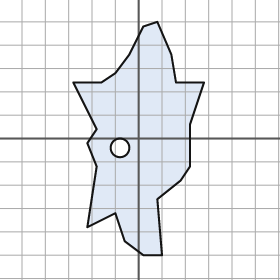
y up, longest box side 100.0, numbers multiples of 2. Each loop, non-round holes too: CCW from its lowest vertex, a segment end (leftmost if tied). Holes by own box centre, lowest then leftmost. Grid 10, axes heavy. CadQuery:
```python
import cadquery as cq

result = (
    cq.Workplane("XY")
    .moveTo(2.0, -50.0)
    .lineTo(10.0, -50.0)
    .lineTo(8.0, -26.0)
    .lineTo(18.0, -18.0)
    .lineTo(22.0, -12.0)
    .lineTo(22.0, 6.0)
    .lineTo(28.0, 24.0)
    .lineTo(16.0, 24.0)
    .lineTo(14.0, 36.0)
    .lineTo(8.0, 50.0)
    .lineTo(2.0, 48.0)
    .lineTo(-4.0, 36.0)
    .lineTo(-10.0, 28.0)
    .lineTo(-16.0, 24.0)
    .lineTo(-28.0, 24.0)
    .lineTo(-18.0, 4.0)
    .lineTo(-22.0, -2.0)
    .lineTo(-18.0, -12.0)
    .lineTo(-22.0, -38.0)
    .lineTo(-10.0, -32.0)
    .lineTo(-6.0, -44.0)
    .close()
    .moveTo(-8.0, -4.0)
    .circle(4.0)
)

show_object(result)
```